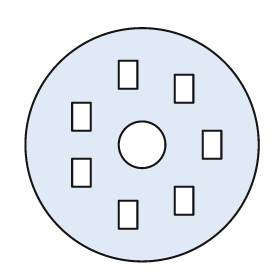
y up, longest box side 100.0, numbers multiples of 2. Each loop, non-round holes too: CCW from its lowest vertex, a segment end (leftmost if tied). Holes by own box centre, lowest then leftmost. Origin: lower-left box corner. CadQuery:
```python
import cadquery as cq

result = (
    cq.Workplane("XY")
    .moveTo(50.0, 50.0)
    .circle(50.0)
    .moveTo(40.0, 14.0)
    .lineTo(48.0, 14.0)
    .lineTo(48.0, 26.0)
    .lineTo(40.0, 26.0)
    .close()
    .moveTo(64.0, 20.0)
    .lineTo(72.0, 20.0)
    .lineTo(72.0, 32.0)
    .lineTo(64.0, 32.0)
    .close()
    .moveTo(20.0, 32.0)
    .lineTo(28.0, 32.0)
    .lineTo(28.0, 44.0)
    .lineTo(20.0, 44.0)
    .close()
    .moveTo(50.0, 50.0)
    .circle(10.0)
    .moveTo(76.0, 44.0)
    .lineTo(84.0, 44.0)
    .lineTo(84.0, 56.0)
    .lineTo(76.0, 56.0)
    .close()
    .moveTo(20.0, 56.0)
    .lineTo(28.0, 56.0)
    .lineTo(28.0, 68.0)
    .lineTo(20.0, 68.0)
    .close()
    .moveTo(64.0, 68.0)
    .lineTo(72.0, 68.0)
    .lineTo(72.0, 80.0)
    .lineTo(64.0, 80.0)
    .close()
    .moveTo(40.0, 74.0)
    .lineTo(48.0, 74.0)
    .lineTo(48.0, 86.0)
    .lineTo(40.0, 86.0)
    .close()
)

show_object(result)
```